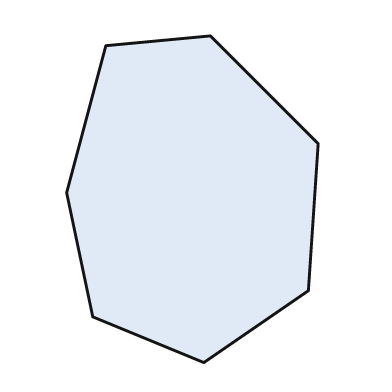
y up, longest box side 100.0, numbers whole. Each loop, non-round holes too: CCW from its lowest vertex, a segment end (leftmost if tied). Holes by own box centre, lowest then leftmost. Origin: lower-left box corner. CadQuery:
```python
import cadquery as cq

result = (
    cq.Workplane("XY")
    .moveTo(42.0, 0.0)
    .lineTo(74.0, 22.0)
    .lineTo(77.0, 67.0)
    .lineTo(44.0, 100.0)
    .lineTo(12.0, 97.0)
    .lineTo(0.0, 52.0)
    .lineTo(8.0, 14.0)
    .close()
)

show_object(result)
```